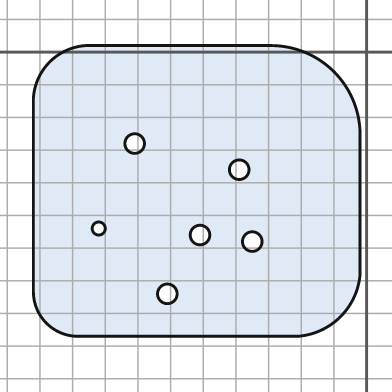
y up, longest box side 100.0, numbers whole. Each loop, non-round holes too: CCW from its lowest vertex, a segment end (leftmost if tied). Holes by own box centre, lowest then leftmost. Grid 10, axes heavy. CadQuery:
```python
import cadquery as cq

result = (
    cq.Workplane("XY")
    .moveTo(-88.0, -87.0)
    .lineTo(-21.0, -87.0)
    .threePointArc((-8.0, -81.0), (-2.0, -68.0))
    .lineTo(-2.0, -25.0)
    .threePointArc((-10.0, -6.0), (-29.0, 2.0))
    .lineTo(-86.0, 2.0)
    .threePointArc((-97.0, -3.0), (-102.0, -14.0))
    .lineTo(-102.0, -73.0)
    .threePointArc((-98.0, -83.0), (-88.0, -87.0))
    .close()
    .moveTo(-61.0, -74.0)
    .circle(3.0)
    .moveTo(-35.0, -58.0)
    .circle(3.0)
    .moveTo(-51.0, -56.0)
    .circle(3.0)
    .moveTo(-82.0, -54.0)
    .circle(2.0)
    .moveTo(-39.0, -36.0)
    .circle(3.0)
    .moveTo(-71.0, -28.0)
    .circle(3.0)
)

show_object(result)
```